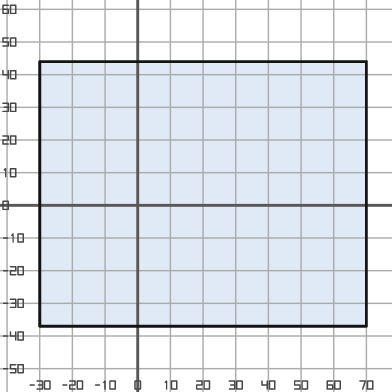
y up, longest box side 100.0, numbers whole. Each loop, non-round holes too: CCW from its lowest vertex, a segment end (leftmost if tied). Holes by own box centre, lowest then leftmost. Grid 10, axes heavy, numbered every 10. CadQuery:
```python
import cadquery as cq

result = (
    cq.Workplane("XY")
    .moveTo(-30.0, -37.0)
    .lineTo(70.0, -37.0)
    .lineTo(70.0, 44.0)
    .lineTo(-30.0, 44.0)
    .close()
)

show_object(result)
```